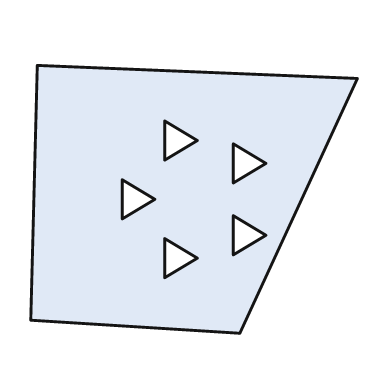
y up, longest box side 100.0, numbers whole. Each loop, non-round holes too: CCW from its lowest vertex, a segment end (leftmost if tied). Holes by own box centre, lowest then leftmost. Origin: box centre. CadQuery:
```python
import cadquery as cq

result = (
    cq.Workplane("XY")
    .moveTo(14.0, -41.0)
    .lineTo(50.0, 37.0)
    .lineTo(-48.0, 41.0)
    .lineTo(-50.0, -37.0)
    .close()
    .moveTo(-9.0, -24.0)
    .lineTo(1.0, -18.0)
    .lineTo(-9.0, -12.0)
    .close()
    .moveTo(12.0, -17.0)
    .lineTo(22.0, -11.0)
    .lineTo(12.0, -5.0)
    .close()
    .moveTo(-22.0, -6.0)
    .lineTo(-12.0, 0.0)
    .lineTo(-22.0, 6.0)
    .close()
    .moveTo(12.0, 5.0)
    .lineTo(22.0, 11.0)
    .lineTo(12.0, 17.0)
    .close()
    .moveTo(-9.0, 12.0)
    .lineTo(1.0, 18.0)
    .lineTo(-9.0, 24.0)
    .close()
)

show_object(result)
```